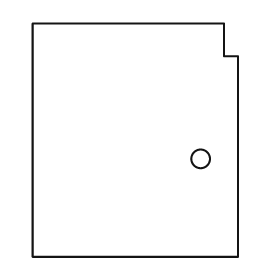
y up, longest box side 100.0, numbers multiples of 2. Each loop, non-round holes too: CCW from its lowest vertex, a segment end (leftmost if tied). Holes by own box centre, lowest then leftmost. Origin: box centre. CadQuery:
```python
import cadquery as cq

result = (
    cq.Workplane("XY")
    .moveTo(-44.0, -50.0)
    .lineTo(44.0, -50.0)
    .lineTo(44.0, 36.0)
    .lineTo(38.0, 36.0)
    .lineTo(38.0, 50.0)
    .lineTo(-44.0, 50.0)
    .close()
    .moveTo(28.0, -8.0)
    .circle(4.0)
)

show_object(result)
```